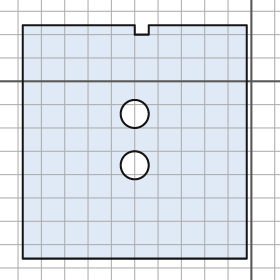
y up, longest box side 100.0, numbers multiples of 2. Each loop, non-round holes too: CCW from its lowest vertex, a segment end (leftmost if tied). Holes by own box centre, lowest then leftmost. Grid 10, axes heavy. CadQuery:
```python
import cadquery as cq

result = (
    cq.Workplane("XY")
    .moveTo(-98.0, -76.0)
    .lineTo(-2.0, -76.0)
    .lineTo(-2.0, 24.0)
    .lineTo(-44.0, 24.0)
    .lineTo(-44.0, 20.0)
    .lineTo(-50.0, 20.0)
    .lineTo(-50.0, 24.0)
    .lineTo(-98.0, 24.0)
    .close()
    .moveTo(-50.0, -36.0)
    .circle(6.0)
    .moveTo(-50.0, -14.0)
    .circle(6.0)
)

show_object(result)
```